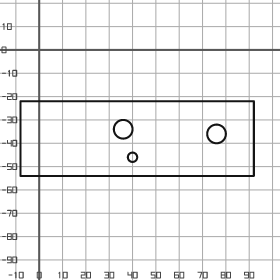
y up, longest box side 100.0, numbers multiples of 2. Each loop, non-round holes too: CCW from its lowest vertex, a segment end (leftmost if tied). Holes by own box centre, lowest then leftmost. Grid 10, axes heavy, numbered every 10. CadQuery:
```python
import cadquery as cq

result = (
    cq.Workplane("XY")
    .moveTo(-8.0, -54.0)
    .lineTo(92.0, -54.0)
    .lineTo(92.0, -22.0)
    .lineTo(-8.0, -22.0)
    .close()
    .moveTo(40.0, -46.0)
    .circle(2.0)
    .moveTo(76.0, -36.0)
    .circle(4.0)
    .moveTo(36.0, -34.0)
    .circle(4.0)
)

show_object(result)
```